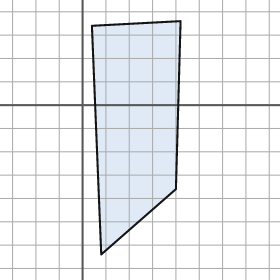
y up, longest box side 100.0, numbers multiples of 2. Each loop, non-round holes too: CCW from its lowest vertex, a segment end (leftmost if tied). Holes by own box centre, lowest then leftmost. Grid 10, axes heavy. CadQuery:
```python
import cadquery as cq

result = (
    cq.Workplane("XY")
    .moveTo(8.0, -64.0)
    .lineTo(40.0, -36.0)
    .lineTo(42.0, 36.0)
    .lineTo(4.0, 34.0)
    .close()
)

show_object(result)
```